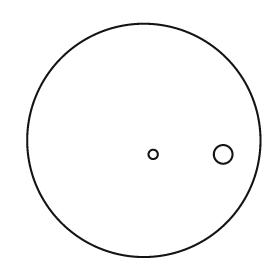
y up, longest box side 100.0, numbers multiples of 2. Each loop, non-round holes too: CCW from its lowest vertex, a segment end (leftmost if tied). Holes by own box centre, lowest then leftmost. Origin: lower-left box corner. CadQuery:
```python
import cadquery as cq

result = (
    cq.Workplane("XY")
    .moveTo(50.0, 50.0)
    .circle(50.0)
    .moveTo(54.0, 44.0)
    .circle(2.0)
    .moveTo(84.0, 44.0)
    .circle(4.0)
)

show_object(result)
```